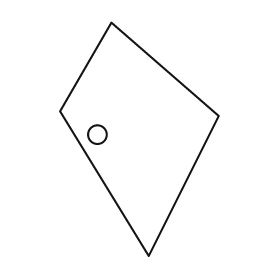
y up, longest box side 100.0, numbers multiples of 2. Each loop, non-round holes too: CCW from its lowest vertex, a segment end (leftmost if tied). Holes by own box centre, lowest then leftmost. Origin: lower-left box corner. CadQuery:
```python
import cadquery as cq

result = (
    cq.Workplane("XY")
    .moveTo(38.0, 0.0)
    .lineTo(68.0, 60.0)
    .lineTo(22.0, 100.0)
    .lineTo(0.0, 62.0)
    .close()
    .moveTo(16.0, 52.0)
    .circle(4.0)
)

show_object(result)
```